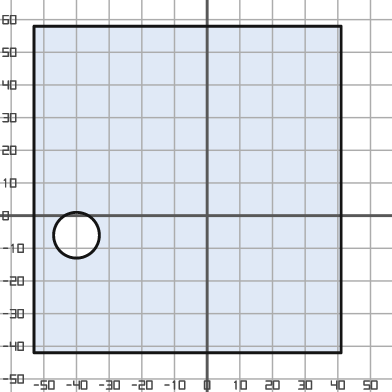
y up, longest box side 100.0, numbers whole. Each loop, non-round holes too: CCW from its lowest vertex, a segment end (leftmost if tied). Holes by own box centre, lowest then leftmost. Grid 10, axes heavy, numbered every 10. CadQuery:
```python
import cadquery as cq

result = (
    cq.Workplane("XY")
    .moveTo(-53.0, -42.0)
    .lineTo(41.0, -42.0)
    .lineTo(41.0, 58.0)
    .lineTo(-53.0, 58.0)
    .close()
    .moveTo(-40.0, -6.0)
    .circle(7.0)
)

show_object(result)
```